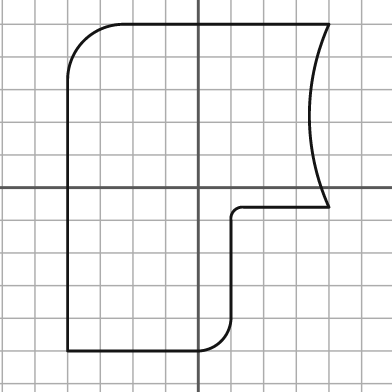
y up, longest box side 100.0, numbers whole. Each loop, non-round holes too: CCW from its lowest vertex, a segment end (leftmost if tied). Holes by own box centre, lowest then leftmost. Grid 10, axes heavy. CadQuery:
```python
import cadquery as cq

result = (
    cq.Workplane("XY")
    .moveTo(-40.0, -50.0)
    .lineTo(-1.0, -50.0)
    .threePointArc((7.0, -47.0), (10.0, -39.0))
    .lineTo(10.0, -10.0)
    .threePointArc((11.0, -7.0), (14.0, -6.0))
    .lineTo(40.0, -6.0)
    .threePointArc((34.0, 22.0), (40.0, 50.0))
    .lineTo(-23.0, 50.0)
    .threePointArc((-35.0, 45.0), (-40.0, 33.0))
    .close()
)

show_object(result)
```